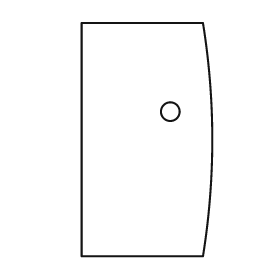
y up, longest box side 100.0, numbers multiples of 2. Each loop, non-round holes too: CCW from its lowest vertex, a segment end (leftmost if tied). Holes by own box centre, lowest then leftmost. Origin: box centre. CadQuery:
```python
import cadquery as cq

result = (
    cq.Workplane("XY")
    .moveTo(-28.0, -50.0)
    .lineTo(24.0, -50.0)
    .threePointArc((28.0, 0.0), (24.0, 50.0))
    .lineTo(-28.0, 50.0)
    .close()
    .moveTo(10.0, 12.0)
    .circle(4.0)
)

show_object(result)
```